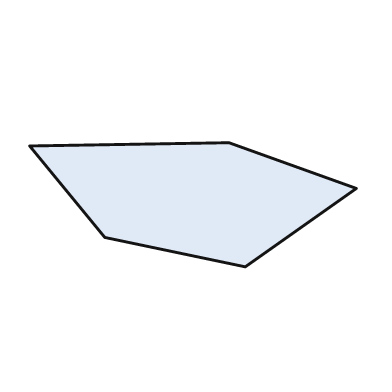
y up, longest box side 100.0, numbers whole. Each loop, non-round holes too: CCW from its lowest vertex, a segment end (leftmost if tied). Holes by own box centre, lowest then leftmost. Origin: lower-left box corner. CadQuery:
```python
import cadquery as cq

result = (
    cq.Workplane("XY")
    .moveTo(66.0, 0.0)
    .lineTo(100.0, 24.0)
    .lineTo(61.0, 38.0)
    .lineTo(0.0, 37.0)
    .lineTo(23.0, 9.0)
    .close()
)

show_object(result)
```